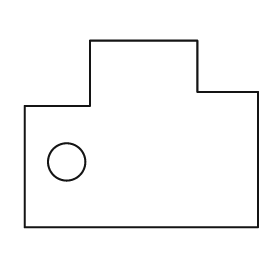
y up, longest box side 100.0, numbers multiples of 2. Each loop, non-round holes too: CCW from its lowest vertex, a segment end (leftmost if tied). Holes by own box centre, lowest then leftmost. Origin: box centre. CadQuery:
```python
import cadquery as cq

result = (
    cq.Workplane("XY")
    .moveTo(-50.0, -40.0)
    .lineTo(50.0, -40.0)
    .lineTo(50.0, 18.0)
    .lineTo(24.0, 18.0)
    .lineTo(24.0, 40.0)
    .lineTo(-22.0, 40.0)
    .lineTo(-22.0, 12.0)
    .lineTo(-50.0, 12.0)
    .close()
    .moveTo(-32.0, -12.0)
    .circle(8.0)
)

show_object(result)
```